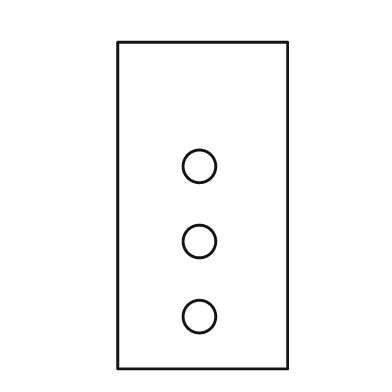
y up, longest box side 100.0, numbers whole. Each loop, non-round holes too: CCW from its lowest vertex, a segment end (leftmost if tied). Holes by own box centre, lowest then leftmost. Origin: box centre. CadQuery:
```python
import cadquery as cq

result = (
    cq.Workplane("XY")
    .moveTo(-26.0, -50.0)
    .lineTo(26.0, -50.0)
    .lineTo(26.0, 50.0)
    .lineTo(-26.0, 50.0)
    .close()
    .moveTo(-1.0, -34.0)
    .circle(5.0)
    .moveTo(-1.0, -11.0)
    .circle(5.0)
    .moveTo(-1.0, 12.0)
    .circle(5.0)
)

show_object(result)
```